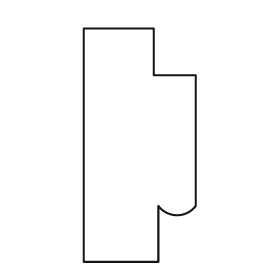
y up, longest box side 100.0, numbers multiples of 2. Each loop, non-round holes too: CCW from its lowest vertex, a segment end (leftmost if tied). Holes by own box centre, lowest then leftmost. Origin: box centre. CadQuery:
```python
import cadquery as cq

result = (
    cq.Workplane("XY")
    .moveTo(-24.0, -50.0)
    .lineTo(8.0, -50.0)
    .lineTo(8.0, -26.0)
    .threePointArc((16.0, -30.0), (24.0, -26.0))
    .lineTo(24.0, 30.0)
    .lineTo(6.0, 30.0)
    .lineTo(6.0, 50.0)
    .lineTo(-24.0, 50.0)
    .close()
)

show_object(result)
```